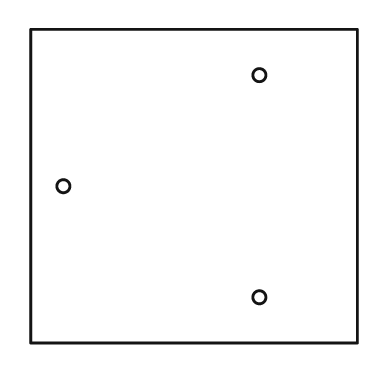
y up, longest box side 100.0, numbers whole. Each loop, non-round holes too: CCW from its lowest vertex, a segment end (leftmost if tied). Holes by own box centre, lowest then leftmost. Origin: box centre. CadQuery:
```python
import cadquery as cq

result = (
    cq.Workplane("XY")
    .moveTo(-50.0, -48.0)
    .lineTo(50.0, -48.0)
    .lineTo(50.0, 48.0)
    .lineTo(-50.0, 48.0)
    .close()
    .moveTo(20.0, -34.0)
    .circle(2.0)
    .moveTo(-40.0, 0.0)
    .circle(2.0)
    .moveTo(20.0, 34.0)
    .circle(2.0)
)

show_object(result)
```